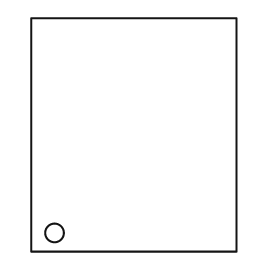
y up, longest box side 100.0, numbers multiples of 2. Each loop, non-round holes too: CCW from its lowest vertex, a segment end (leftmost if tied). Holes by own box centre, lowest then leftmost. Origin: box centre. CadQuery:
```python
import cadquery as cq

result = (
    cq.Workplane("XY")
    .moveTo(-44.0, -50.0)
    .lineTo(44.0, -50.0)
    .lineTo(44.0, 50.0)
    .lineTo(-44.0, 50.0)
    .close()
    .moveTo(-34.0, -42.0)
    .circle(4.0)
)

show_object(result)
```